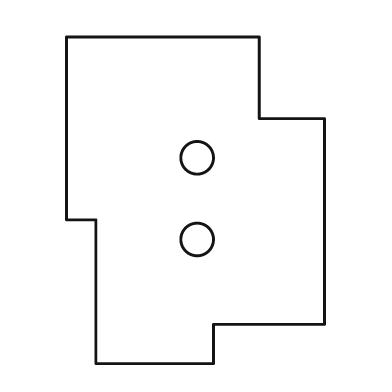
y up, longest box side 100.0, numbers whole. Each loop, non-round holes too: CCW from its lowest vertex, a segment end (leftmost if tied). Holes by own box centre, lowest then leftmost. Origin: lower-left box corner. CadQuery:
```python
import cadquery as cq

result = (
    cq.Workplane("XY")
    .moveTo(9.0, 0.0)
    .lineTo(45.0, 0.0)
    .lineTo(45.0, 12.0)
    .lineTo(79.0, 12.0)
    .lineTo(79.0, 75.0)
    .lineTo(59.0, 75.0)
    .lineTo(59.0, 100.0)
    .lineTo(0.0, 100.0)
    .lineTo(0.0, 44.0)
    .lineTo(9.0, 44.0)
    .close()
    .moveTo(40.0, 38.0)
    .circle(5.0)
    .moveTo(40.0, 63.0)
    .circle(5.0)
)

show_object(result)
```